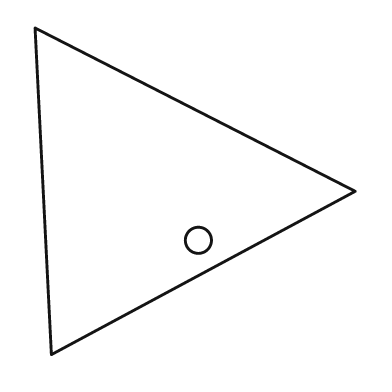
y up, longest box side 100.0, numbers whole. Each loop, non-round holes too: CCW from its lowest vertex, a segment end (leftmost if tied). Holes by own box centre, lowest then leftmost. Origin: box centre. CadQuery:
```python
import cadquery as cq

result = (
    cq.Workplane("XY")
    .moveTo(-44.0, -50.0)
    .lineTo(49.0, 0.0)
    .lineTo(-49.0, 50.0)
    .close()
    .moveTo(1.0, -15.0)
    .circle(4.0)
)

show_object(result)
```